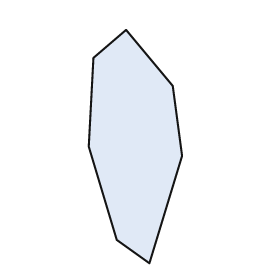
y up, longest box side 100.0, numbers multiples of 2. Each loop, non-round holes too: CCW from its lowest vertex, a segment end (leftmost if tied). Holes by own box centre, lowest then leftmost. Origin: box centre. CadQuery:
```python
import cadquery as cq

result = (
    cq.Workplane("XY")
    .moveTo(6.0, -50.0)
    .lineTo(20.0, -4.0)
    .lineTo(16.0, 26.0)
    .lineTo(-4.0, 50.0)
    .lineTo(-18.0, 38.0)
    .lineTo(-20.0, 0.0)
    .lineTo(-8.0, -40.0)
    .close()
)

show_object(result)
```